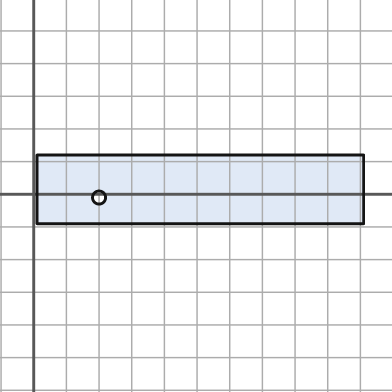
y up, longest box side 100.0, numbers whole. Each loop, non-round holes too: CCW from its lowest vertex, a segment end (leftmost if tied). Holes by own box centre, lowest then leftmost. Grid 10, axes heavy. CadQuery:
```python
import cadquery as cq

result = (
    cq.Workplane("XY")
    .moveTo(1.0, -9.0)
    .lineTo(101.0, -9.0)
    .lineTo(101.0, 12.0)
    .lineTo(1.0, 12.0)
    .close()
    .moveTo(20.0, -1.0)
    .circle(2.0)
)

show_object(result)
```